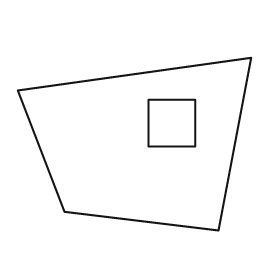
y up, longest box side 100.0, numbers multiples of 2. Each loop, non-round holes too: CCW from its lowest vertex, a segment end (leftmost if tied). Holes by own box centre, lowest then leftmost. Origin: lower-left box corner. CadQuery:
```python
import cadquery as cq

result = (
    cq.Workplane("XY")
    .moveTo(86.0, 0.0)
    .lineTo(100.0, 74.0)
    .lineTo(0.0, 60.0)
    .lineTo(20.0, 8.0)
    .close()
    .moveTo(56.0, 36.0)
    .lineTo(76.0, 36.0)
    .lineTo(76.0, 56.0)
    .lineTo(56.0, 56.0)
    .close()
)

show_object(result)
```